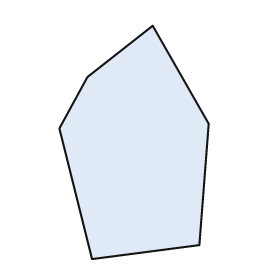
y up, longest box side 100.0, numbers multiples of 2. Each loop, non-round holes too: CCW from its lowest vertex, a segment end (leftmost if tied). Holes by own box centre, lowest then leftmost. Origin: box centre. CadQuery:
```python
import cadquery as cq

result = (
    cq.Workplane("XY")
    .moveTo(-18.0, -50.0)
    .lineTo(28.0, -44.0)
    .lineTo(32.0, 8.0)
    .lineTo(8.0, 50.0)
    .lineTo(-20.0, 28.0)
    .lineTo(-32.0, 6.0)
    .close()
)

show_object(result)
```